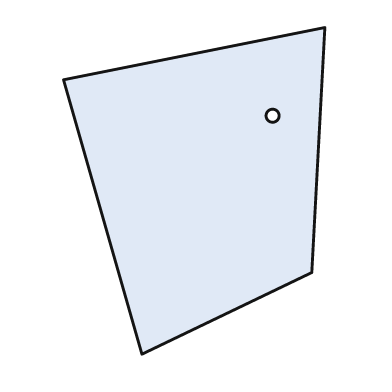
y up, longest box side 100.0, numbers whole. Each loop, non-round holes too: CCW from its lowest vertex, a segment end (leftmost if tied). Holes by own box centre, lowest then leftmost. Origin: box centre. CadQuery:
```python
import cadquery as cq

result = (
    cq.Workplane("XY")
    .moveTo(-16.0, -50.0)
    .lineTo(36.0, -25.0)
    .lineTo(40.0, 50.0)
    .lineTo(-40.0, 34.0)
    .close()
    .moveTo(24.0, 23.0)
    .circle(2.0)
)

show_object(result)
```